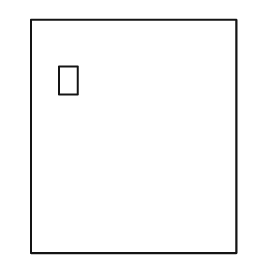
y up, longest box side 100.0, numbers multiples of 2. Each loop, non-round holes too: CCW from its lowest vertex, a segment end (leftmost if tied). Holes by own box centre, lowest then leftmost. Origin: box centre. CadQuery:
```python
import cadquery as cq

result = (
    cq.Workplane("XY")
    .moveTo(-44.0, -50.0)
    .lineTo(44.0, -50.0)
    .lineTo(44.0, 50.0)
    .lineTo(-44.0, 50.0)
    .close()
    .moveTo(-32.0, 18.0)
    .lineTo(-24.0, 18.0)
    .lineTo(-24.0, 30.0)
    .lineTo(-32.0, 30.0)
    .close()
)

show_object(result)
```